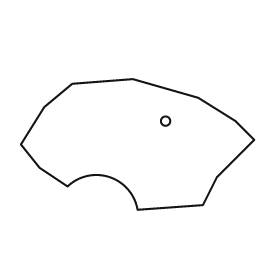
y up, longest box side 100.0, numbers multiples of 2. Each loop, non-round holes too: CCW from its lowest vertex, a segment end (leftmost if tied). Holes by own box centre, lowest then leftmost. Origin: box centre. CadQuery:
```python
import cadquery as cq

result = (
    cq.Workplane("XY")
    .moveTo(0.0, -28.0)
    .lineTo(28.0, -26.0)
    .lineTo(34.0, -14.0)
    .lineTo(50.0, 2.0)
    .lineTo(42.0, 10.0)
    .lineTo(26.0, 20.0)
    .lineTo(-2.0, 28.0)
    .lineTo(-28.0, 26.0)
    .lineTo(-40.0, 16.0)
    .lineTo(-50.0, 0.0)
    .lineTo(-42.0, -10.0)
    .lineTo(-30.0, -18.0)
    .threePointArc((-12.0, -14.0), (0.0, -28.0))
    .close()
    .moveTo(12.0, 10.0)
    .circle(2.0)
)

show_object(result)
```